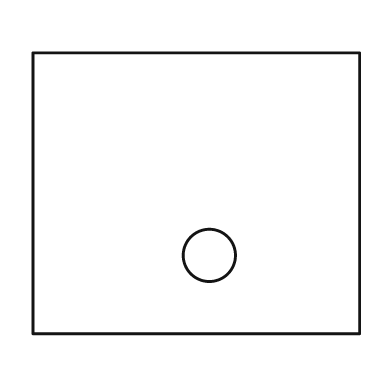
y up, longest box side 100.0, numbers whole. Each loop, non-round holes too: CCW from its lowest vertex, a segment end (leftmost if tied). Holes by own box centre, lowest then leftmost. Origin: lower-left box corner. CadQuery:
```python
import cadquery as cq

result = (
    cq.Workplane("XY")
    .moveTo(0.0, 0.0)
    .lineTo(100.0, 0.0)
    .lineTo(100.0, 86.0)
    .lineTo(0.0, 86.0)
    .close()
    .moveTo(54.0, 24.0)
    .circle(8.0)
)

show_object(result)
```